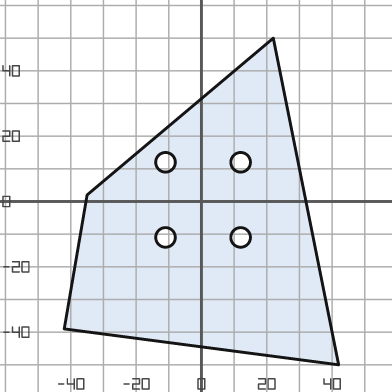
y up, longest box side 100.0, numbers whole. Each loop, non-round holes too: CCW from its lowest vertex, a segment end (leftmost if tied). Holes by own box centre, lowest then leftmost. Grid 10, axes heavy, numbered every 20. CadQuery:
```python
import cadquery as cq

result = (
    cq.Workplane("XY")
    .moveTo(42.0, -50.0)
    .lineTo(22.0, 50.0)
    .lineTo(-35.0, 2.0)
    .lineTo(-42.0, -39.0)
    .close()
    .moveTo(-11.0, -11.0)
    .circle(3.0)
    .moveTo(12.0, -11.0)
    .circle(3.0)
    .moveTo(-11.0, 12.0)
    .circle(3.0)
    .moveTo(12.0, 12.0)
    .circle(3.0)
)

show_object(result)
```